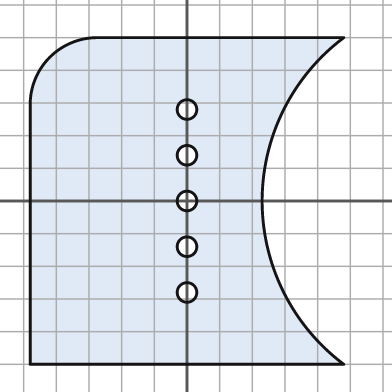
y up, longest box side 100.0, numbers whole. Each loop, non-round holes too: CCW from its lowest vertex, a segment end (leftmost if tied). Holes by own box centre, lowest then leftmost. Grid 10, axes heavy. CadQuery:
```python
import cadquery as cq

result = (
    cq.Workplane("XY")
    .moveTo(-48.0, -50.0)
    .lineTo(48.0, -50.0)
    .threePointArc((23.0, 0.0), (48.0, 50.0))
    .lineTo(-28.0, 50.0)
    .threePointArc((-42.0, 44.0), (-48.0, 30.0))
    .close()
    .moveTo(0.0, -28.0)
    .circle(3.0)
    .moveTo(0.0, -14.0)
    .circle(3.0)
    .moveTo(0.0, 0.0)
    .circle(3.0)
    .moveTo(0.0, 14.0)
    .circle(3.0)
    .moveTo(0.0, 28.0)
    .circle(3.0)
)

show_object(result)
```